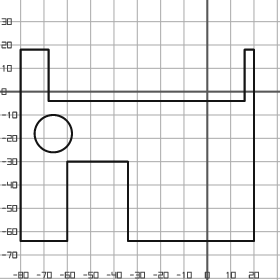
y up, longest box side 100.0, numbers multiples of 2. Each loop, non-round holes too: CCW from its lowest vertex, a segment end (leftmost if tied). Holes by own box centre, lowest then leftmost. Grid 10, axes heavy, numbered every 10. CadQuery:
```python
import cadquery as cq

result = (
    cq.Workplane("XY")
    .moveTo(-80.0, -64.0)
    .lineTo(-60.0, -64.0)
    .lineTo(-60.0, -30.0)
    .lineTo(-34.0, -30.0)
    .lineTo(-34.0, -64.0)
    .lineTo(20.0, -64.0)
    .lineTo(20.0, 18.0)
    .lineTo(16.0, 18.0)
    .lineTo(16.0, -4.0)
    .lineTo(-68.0, -4.0)
    .lineTo(-68.0, 18.0)
    .lineTo(-80.0, 18.0)
    .close()
    .moveTo(-66.0, -18.0)
    .circle(8.0)
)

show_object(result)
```